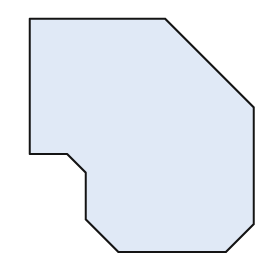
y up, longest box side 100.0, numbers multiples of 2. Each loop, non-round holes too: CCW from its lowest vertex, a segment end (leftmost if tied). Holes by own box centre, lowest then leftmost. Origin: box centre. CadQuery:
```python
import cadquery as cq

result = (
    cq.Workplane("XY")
    .moveTo(-10.0, -50.0)
    .lineTo(36.0, -50.0)
    .lineTo(48.0, -38.0)
    .lineTo(48.0, 12.0)
    .lineTo(10.0, 50.0)
    .lineTo(-48.0, 50.0)
    .lineTo(-48.0, -8.0)
    .lineTo(-32.0, -8.0)
    .lineTo(-24.0, -16.0)
    .lineTo(-24.0, -36.0)
    .close()
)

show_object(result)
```